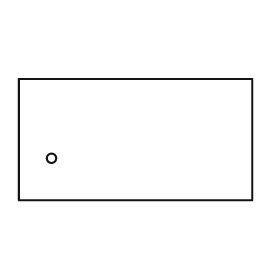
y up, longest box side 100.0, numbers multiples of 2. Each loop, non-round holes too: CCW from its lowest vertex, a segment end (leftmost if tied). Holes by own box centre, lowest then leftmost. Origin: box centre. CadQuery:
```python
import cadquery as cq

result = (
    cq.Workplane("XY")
    .moveTo(-50.0, -26.0)
    .lineTo(50.0, -26.0)
    .lineTo(50.0, 26.0)
    .lineTo(-50.0, 26.0)
    .close()
    .moveTo(-36.0, -8.0)
    .circle(2.0)
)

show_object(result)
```